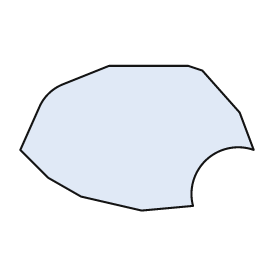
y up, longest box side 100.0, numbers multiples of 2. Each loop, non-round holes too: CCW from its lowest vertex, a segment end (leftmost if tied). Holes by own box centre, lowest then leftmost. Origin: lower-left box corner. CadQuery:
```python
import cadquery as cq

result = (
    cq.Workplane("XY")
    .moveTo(52.0, 0.0)
    .lineTo(74.0, 2.0)
    .threePointArc((80.0, 22.0), (100.0, 26.0))
    .lineTo(94.0, 42.0)
    .lineTo(78.0, 60.0)
    .lineTo(72.0, 62.0)
    .lineTo(38.0, 62.0)
    .lineTo(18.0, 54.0)
    .threePointArc((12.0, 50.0), (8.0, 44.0))
    .lineTo(0.0, 26.0)
    .lineTo(12.0, 14.0)
    .lineTo(26.0, 6.0)
    .close()
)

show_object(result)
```